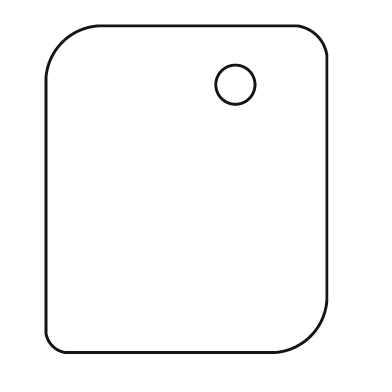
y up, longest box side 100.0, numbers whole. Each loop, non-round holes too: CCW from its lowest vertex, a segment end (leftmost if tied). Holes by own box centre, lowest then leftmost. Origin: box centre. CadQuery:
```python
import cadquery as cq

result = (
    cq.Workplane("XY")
    .moveTo(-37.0, -50.0)
    .lineTo(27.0, -50.0)
    .threePointArc((38.0, -45.0), (43.0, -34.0))
    .lineTo(43.0, 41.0)
    .threePointArc((40.0, 47.0), (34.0, 50.0))
    .lineTo(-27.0, 50.0)
    .threePointArc((-38.0, 45.0), (-43.0, 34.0))
    .lineTo(-43.0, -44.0)
    .threePointArc((-41.0, -48.0), (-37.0, -50.0))
    .close()
    .moveTo(15.0, 32.0)
    .circle(6.0)
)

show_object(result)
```